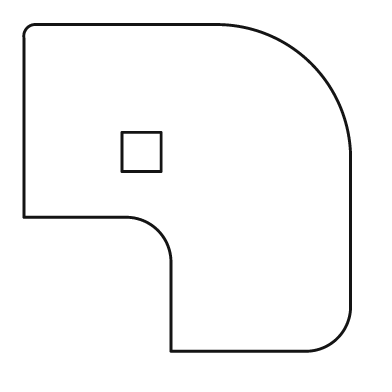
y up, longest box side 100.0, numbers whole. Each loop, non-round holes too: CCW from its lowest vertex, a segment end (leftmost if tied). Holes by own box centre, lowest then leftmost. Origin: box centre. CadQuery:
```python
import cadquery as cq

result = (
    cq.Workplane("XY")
    .moveTo(-5.0, -50.0)
    .lineTo(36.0, -50.0)
    .threePointArc((46.0, -46.0), (50.0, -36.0))
    .lineTo(50.0, 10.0)
    .threePointArc((38.0, 38.0), (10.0, 50.0))
    .lineTo(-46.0, 50.0)
    .threePointArc((-49.0, 49.0), (-50.0, 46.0))
    .lineTo(-50.0, -9.0)
    .lineTo(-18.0, -9.0)
    .threePointArc((-9.0, -13.0), (-5.0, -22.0))
    .close()
    .moveTo(-20.0, 5.0)
    .lineTo(-8.0, 5.0)
    .lineTo(-8.0, 17.0)
    .lineTo(-20.0, 17.0)
    .close()
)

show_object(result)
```